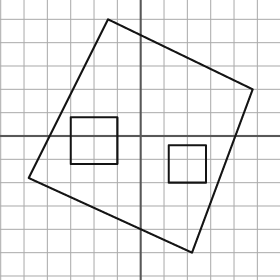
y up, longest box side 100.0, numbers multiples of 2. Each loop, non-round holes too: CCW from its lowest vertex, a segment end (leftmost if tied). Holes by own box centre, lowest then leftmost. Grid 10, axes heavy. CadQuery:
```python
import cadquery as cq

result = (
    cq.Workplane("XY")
    .moveTo(22.0, -50.0)
    .lineTo(48.0, 20.0)
    .lineTo(-14.0, 50.0)
    .lineTo(-48.0, -18.0)
    .close()
    .moveTo(12.0, -20.0)
    .lineTo(28.0, -20.0)
    .lineTo(28.0, -4.0)
    .lineTo(12.0, -4.0)
    .close()
    .moveTo(-30.0, -12.0)
    .lineTo(-10.0, -12.0)
    .lineTo(-10.0, 8.0)
    .lineTo(-30.0, 8.0)
    .close()
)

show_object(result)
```